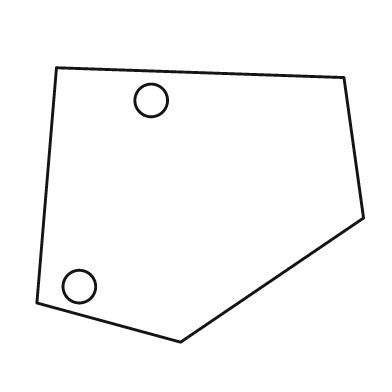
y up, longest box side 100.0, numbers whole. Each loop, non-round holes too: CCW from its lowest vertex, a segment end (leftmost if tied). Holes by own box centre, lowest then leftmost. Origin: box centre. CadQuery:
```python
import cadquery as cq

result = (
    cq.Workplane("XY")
    .moveTo(-6.0, -42.0)
    .lineTo(50.0, -4.0)
    .lineTo(44.0, 39.0)
    .lineTo(-44.0, 42.0)
    .lineTo(-50.0, -30.0)
    .close()
    .moveTo(-37.0, -25.0)
    .circle(5.0)
    .moveTo(-15.0, 32.0)
    .circle(5.0)
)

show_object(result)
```